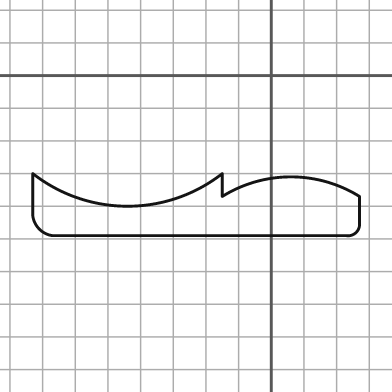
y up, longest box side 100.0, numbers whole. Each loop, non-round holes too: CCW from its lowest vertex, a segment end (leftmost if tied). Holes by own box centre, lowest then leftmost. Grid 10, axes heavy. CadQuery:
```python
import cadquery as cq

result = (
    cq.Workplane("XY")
    .moveTo(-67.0, -49.0)
    .lineTo(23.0, -49.0)
    .threePointArc((26.0, -48.0), (27.0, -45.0))
    .lineTo(27.0, -37.0)
    .threePointArc((6.0, -31.0), (-15.0, -37.0))
    .lineTo(-15.0, -30.0)
    .threePointArc((-44.0, -40.0), (-73.0, -30.0))
    .lineTo(-73.0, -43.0)
    .threePointArc((-71.0, -47.0), (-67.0, -49.0))
    .close()
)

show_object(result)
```